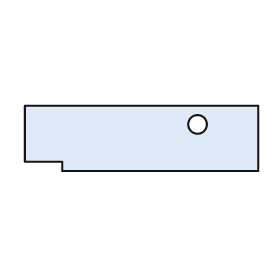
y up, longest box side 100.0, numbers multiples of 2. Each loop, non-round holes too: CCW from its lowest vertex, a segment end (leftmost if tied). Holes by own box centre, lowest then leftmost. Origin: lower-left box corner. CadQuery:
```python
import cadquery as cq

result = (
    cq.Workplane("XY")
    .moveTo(16.0, 0.0)
    .lineTo(100.0, 0.0)
    .lineTo(100.0, 28.0)
    .lineTo(0.0, 28.0)
    .lineTo(0.0, 4.0)
    .lineTo(16.0, 4.0)
    .close()
    .moveTo(74.0, 20.0)
    .circle(4.0)
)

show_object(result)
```